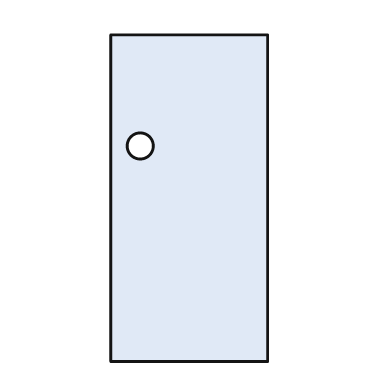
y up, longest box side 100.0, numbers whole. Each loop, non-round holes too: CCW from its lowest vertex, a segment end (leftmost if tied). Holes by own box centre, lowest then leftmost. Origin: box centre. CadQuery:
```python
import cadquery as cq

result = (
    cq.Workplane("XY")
    .moveTo(-24.0, -50.0)
    .lineTo(24.0, -50.0)
    .lineTo(24.0, 50.0)
    .lineTo(-24.0, 50.0)
    .close()
    .moveTo(-15.0, 16.0)
    .circle(4.0)
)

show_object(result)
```